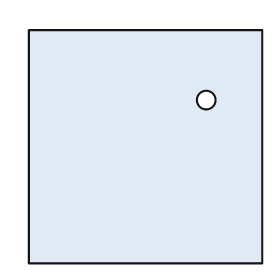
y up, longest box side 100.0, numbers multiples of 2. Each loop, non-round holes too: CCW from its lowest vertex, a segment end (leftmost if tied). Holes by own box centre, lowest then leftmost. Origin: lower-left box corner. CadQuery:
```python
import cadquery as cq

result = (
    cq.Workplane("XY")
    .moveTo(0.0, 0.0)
    .lineTo(100.0, 0.0)
    .lineTo(100.0, 100.0)
    .lineTo(0.0, 100.0)
    .close()
    .moveTo(76.0, 70.0)
    .circle(4.0)
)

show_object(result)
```